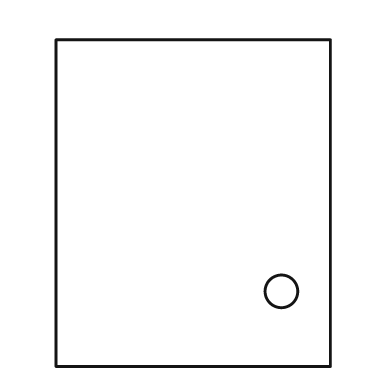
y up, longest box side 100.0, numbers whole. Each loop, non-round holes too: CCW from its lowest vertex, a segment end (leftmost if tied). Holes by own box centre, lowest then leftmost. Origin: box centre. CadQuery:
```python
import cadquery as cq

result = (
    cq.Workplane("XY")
    .moveTo(-42.0, -50.0)
    .lineTo(42.0, -50.0)
    .lineTo(42.0, 50.0)
    .lineTo(-42.0, 50.0)
    .close()
    .moveTo(27.0, -27.0)
    .circle(5.0)
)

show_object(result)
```